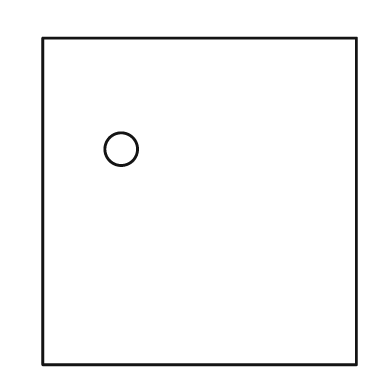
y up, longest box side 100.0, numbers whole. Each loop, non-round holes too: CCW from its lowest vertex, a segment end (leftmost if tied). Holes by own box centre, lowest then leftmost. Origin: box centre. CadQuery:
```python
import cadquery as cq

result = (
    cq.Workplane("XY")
    .moveTo(-48.0, -50.0)
    .lineTo(48.0, -50.0)
    .lineTo(48.0, 50.0)
    .lineTo(-48.0, 50.0)
    .close()
    .moveTo(-24.0, 16.0)
    .circle(5.0)
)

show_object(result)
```